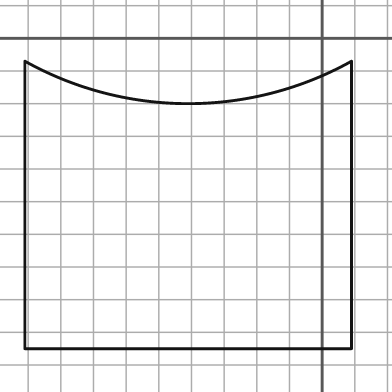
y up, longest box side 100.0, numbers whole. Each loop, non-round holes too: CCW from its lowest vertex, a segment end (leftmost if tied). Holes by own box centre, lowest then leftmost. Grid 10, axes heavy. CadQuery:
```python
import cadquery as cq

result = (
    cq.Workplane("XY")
    .moveTo(-91.0, -95.0)
    .lineTo(9.0, -95.0)
    .lineTo(9.0, -7.0)
    .threePointArc((-41.0, -20.0), (-91.0, -7.0))
    .close()
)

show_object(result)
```